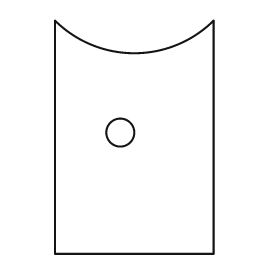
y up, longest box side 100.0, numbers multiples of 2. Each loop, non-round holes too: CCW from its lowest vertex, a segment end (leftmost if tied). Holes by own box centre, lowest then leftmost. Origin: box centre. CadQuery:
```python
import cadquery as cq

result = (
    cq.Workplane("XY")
    .moveTo(-34.0, -50.0)
    .lineTo(34.0, -50.0)
    .lineTo(34.0, 50.0)
    .threePointArc((0.0, 36.0), (-34.0, 50.0))
    .close()
    .moveTo(-6.0, 2.0)
    .circle(6.0)
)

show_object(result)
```